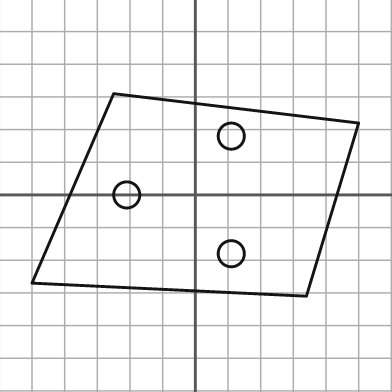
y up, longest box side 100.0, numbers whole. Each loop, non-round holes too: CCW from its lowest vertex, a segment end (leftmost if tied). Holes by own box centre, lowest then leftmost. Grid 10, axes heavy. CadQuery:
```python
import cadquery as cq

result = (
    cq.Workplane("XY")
    .moveTo(34.0, -31.0)
    .lineTo(50.0, 22.0)
    .lineTo(-25.0, 31.0)
    .lineTo(-50.0, -27.0)
    .close()
    .moveTo(11.0, -18.0)
    .circle(4.0)
    .moveTo(-21.0, 0.0)
    .circle(4.0)
    .moveTo(11.0, 18.0)
    .circle(4.0)
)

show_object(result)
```